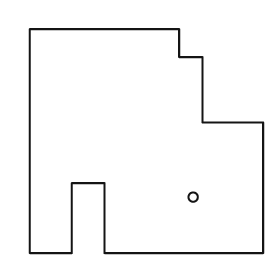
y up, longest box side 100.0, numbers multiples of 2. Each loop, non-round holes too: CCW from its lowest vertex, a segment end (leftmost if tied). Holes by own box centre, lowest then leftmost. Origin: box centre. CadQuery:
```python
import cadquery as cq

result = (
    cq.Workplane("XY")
    .moveTo(-50.0, -48.0)
    .lineTo(-32.0, -48.0)
    .lineTo(-32.0, -18.0)
    .lineTo(-18.0, -18.0)
    .lineTo(-18.0, -48.0)
    .lineTo(50.0, -48.0)
    .lineTo(50.0, 8.0)
    .lineTo(24.0, 8.0)
    .lineTo(24.0, 36.0)
    .lineTo(14.0, 36.0)
    .lineTo(14.0, 48.0)
    .lineTo(-50.0, 48.0)
    .close()
    .moveTo(20.0, -24.0)
    .circle(2.0)
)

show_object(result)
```